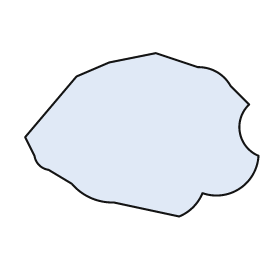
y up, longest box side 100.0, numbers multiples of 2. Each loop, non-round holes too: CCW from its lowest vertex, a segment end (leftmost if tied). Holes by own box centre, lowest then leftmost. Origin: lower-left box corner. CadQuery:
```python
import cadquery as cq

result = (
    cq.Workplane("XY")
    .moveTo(66.0, 0.0)
    .threePointArc((72.0, 4.0), (76.0, 10.0))
    .threePointArc((92.0, 12.0), (100.0, 26.0))
    .threePointArc((92.0, 36.0), (96.0, 48.0))
    .lineTo(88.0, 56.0)
    .threePointArc((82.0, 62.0), (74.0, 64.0))
    .lineTo(56.0, 70.0)
    .lineTo(36.0, 66.0)
    .lineTo(22.0, 60.0)
    .lineTo(0.0, 34.0)
    .lineTo(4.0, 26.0)
    .threePointArc((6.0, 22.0), (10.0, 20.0))
    .lineTo(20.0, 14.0)
    .threePointArc((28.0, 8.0), (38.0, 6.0))
    .close()
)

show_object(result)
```